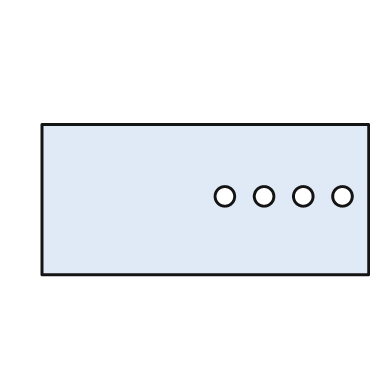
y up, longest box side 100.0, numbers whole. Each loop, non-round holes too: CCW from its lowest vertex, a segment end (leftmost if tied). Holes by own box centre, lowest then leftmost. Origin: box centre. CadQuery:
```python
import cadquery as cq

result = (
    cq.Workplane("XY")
    .moveTo(-50.0, -23.0)
    .lineTo(50.0, -23.0)
    .lineTo(50.0, 23.0)
    .lineTo(-50.0, 23.0)
    .close()
    .moveTo(6.0, 1.0)
    .circle(3.0)
    .moveTo(18.0, 1.0)
    .circle(3.0)
    .moveTo(30.0, 1.0)
    .circle(3.0)
    .moveTo(42.0, 1.0)
    .circle(3.0)
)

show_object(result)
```